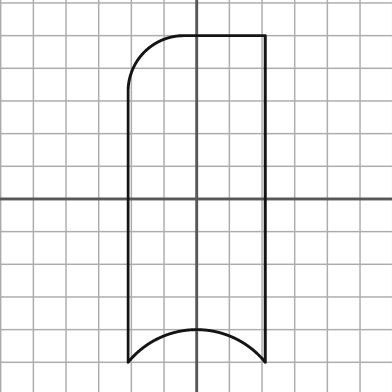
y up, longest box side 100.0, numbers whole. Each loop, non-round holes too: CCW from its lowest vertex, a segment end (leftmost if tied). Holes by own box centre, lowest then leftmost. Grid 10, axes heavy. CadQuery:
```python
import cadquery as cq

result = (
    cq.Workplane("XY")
    .moveTo(-21.0, -50.0)
    .threePointArc((0.0, -40.0), (21.0, -50.0))
    .lineTo(21.0, 50.0)
    .lineTo(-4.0, 50.0)
    .threePointArc((-16.0, 45.0), (-21.0, 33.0))
    .close()
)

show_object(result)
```